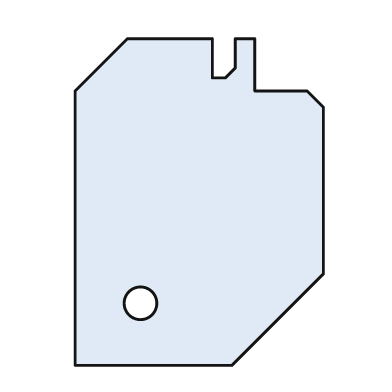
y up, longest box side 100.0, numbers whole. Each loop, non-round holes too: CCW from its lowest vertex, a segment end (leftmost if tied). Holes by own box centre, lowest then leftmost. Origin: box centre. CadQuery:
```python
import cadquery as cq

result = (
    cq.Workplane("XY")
    .moveTo(-38.0, -50.0)
    .lineTo(10.0, -50.0)
    .lineTo(38.0, -22.0)
    .lineTo(38.0, 29.0)
    .lineTo(33.0, 34.0)
    .lineTo(17.0, 34.0)
    .lineTo(17.0, 50.0)
    .lineTo(11.0, 50.0)
    .lineTo(11.0, 41.0)
    .lineTo(8.0, 38.0)
    .lineTo(4.0, 38.0)
    .lineTo(4.0, 50.0)
    .lineTo(-22.0, 50.0)
    .lineTo(-38.0, 34.0)
    .close()
    .moveTo(-18.0, -31.0)
    .circle(5.0)
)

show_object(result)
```